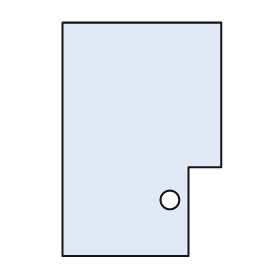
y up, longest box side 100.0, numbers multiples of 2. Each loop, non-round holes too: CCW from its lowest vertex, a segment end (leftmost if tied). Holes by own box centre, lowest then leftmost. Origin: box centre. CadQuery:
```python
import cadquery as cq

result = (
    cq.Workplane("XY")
    .moveTo(-34.0, -50.0)
    .lineTo(20.0, -50.0)
    .lineTo(20.0, -12.0)
    .lineTo(34.0, -12.0)
    .lineTo(34.0, 50.0)
    .lineTo(-34.0, 50.0)
    .close()
    .moveTo(12.0, -26.0)
    .circle(4.0)
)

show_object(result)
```